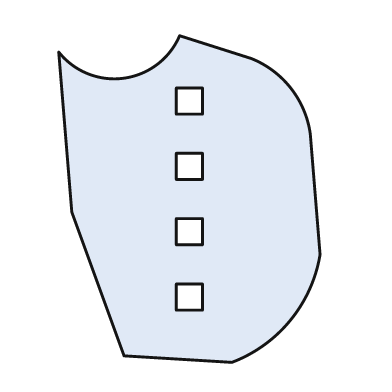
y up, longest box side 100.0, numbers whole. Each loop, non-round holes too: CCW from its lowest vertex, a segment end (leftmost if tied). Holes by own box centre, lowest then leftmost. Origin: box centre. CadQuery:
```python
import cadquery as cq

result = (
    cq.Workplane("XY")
    .moveTo(13.0, -50.0)
    .threePointArc((31.0, -37.0), (40.0, -17.0))
    .lineTo(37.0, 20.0)
    .threePointArc((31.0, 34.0), (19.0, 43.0))
    .lineTo(-3.0, 50.0)
    .threePointArc((-20.0, 37.0), (-40.0, 45.0))
    .lineTo(-36.0, -4.0)
    .lineTo(-20.0, -48.0)
    .close()
    .moveTo(-4.0, -34.0)
    .lineTo(4.0, -34.0)
    .lineTo(4.0, -26.0)
    .lineTo(-4.0, -26.0)
    .close()
    .moveTo(-4.0, -14.0)
    .lineTo(4.0, -14.0)
    .lineTo(4.0, -6.0)
    .lineTo(-4.0, -6.0)
    .close()
    .moveTo(-4.0, 6.0)
    .lineTo(4.0, 6.0)
    .lineTo(4.0, 14.0)
    .lineTo(-4.0, 14.0)
    .close()
    .moveTo(-4.0, 26.0)
    .lineTo(4.0, 26.0)
    .lineTo(4.0, 34.0)
    .lineTo(-4.0, 34.0)
    .close()
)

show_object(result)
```